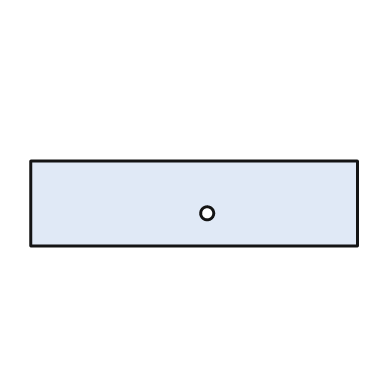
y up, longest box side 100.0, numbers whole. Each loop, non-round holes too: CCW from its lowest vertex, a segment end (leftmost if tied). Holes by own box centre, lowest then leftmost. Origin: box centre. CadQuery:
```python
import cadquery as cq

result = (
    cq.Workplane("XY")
    .moveTo(-50.0, -13.0)
    .lineTo(50.0, -13.0)
    .lineTo(50.0, 13.0)
    .lineTo(-50.0, 13.0)
    .close()
    .moveTo(4.0, -3.0)
    .circle(2.0)
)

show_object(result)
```